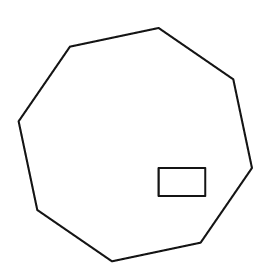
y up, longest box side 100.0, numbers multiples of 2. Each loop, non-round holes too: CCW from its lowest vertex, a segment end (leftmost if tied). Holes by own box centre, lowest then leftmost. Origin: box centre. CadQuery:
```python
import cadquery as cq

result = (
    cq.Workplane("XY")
    .moveTo(-10.0, -50.0)
    .lineTo(28.0, -42.0)
    .lineTo(50.0, -10.0)
    .lineTo(42.0, 28.0)
    .lineTo(10.0, 50.0)
    .lineTo(-28.0, 42.0)
    .lineTo(-50.0, 10.0)
    .lineTo(-42.0, -28.0)
    .close()
    .moveTo(10.0, -22.0)
    .lineTo(30.0, -22.0)
    .lineTo(30.0, -10.0)
    .lineTo(10.0, -10.0)
    .close()
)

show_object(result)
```